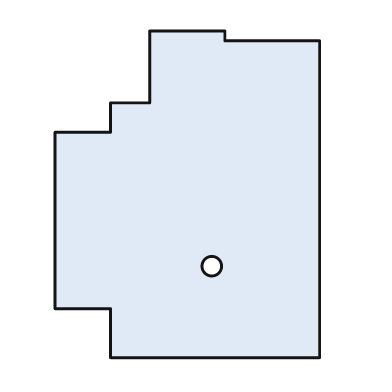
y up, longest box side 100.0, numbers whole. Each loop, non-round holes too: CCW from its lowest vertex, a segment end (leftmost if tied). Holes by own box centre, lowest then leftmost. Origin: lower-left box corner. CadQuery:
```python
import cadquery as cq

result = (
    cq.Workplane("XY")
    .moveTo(17.0, 0.0)
    .lineTo(81.0, 0.0)
    .lineTo(81.0, 97.0)
    .lineTo(52.0, 97.0)
    .lineTo(52.0, 100.0)
    .lineTo(29.0, 100.0)
    .lineTo(29.0, 78.0)
    .lineTo(17.0, 78.0)
    .lineTo(17.0, 69.0)
    .lineTo(0.0, 69.0)
    .lineTo(0.0, 15.0)
    .lineTo(17.0, 15.0)
    .close()
    .moveTo(48.0, 28.0)
    .circle(3.0)
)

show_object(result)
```